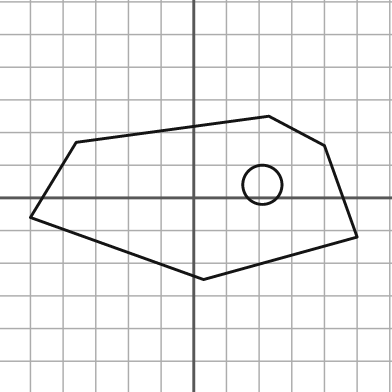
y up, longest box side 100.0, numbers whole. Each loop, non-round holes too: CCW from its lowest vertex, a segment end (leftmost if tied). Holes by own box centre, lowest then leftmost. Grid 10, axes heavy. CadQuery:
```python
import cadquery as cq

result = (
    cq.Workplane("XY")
    .moveTo(3.0, -25.0)
    .lineTo(50.0, -12.0)
    .lineTo(40.0, 16.0)
    .lineTo(23.0, 25.0)
    .lineTo(-36.0, 17.0)
    .lineTo(-50.0, -6.0)
    .close()
    .moveTo(21.0, 4.0)
    .circle(6.0)
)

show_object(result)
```